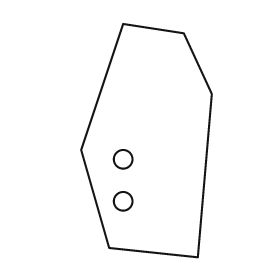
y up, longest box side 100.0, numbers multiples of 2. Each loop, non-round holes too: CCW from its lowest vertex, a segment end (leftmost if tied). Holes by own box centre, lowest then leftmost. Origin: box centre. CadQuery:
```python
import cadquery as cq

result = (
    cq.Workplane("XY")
    .moveTo(22.0, -50.0)
    .lineTo(28.0, 20.0)
    .lineTo(16.0, 46.0)
    .lineTo(-10.0, 50.0)
    .lineTo(-28.0, -4.0)
    .lineTo(-16.0, -46.0)
    .close()
    .moveTo(-10.0, -26.0)
    .circle(4.0)
    .moveTo(-10.0, -8.0)
    .circle(4.0)
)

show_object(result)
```